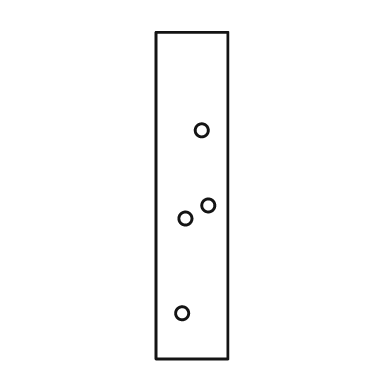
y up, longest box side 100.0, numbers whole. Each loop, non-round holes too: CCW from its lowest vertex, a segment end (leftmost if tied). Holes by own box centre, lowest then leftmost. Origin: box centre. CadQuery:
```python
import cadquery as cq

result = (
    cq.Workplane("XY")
    .moveTo(-11.0, -50.0)
    .lineTo(11.0, -50.0)
    .lineTo(11.0, 50.0)
    .lineTo(-11.0, 50.0)
    .close()
    .moveTo(-3.0, -36.0)
    .circle(2.0)
    .moveTo(-2.0, -7.0)
    .circle(2.0)
    .moveTo(5.0, -3.0)
    .circle(2.0)
    .moveTo(3.0, 20.0)
    .circle(2.0)
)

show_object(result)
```